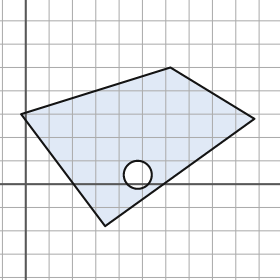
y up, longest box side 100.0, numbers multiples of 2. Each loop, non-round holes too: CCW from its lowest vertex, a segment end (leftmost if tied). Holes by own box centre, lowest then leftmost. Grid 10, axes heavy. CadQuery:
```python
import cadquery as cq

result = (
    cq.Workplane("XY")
    .moveTo(34.0, -18.0)
    .lineTo(98.0, 28.0)
    .lineTo(62.0, 50.0)
    .lineTo(-2.0, 30.0)
    .close()
    .moveTo(48.0, 4.0)
    .circle(6.0)
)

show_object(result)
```